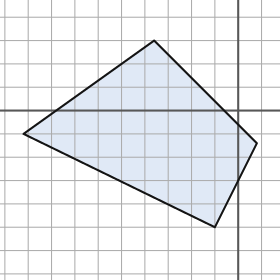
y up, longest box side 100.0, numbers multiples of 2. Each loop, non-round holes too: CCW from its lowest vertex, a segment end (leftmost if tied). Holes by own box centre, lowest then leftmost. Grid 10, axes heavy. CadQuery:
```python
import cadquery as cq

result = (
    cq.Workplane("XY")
    .moveTo(-10.0, -50.0)
    .lineTo(8.0, -14.0)
    .lineTo(-36.0, 30.0)
    .lineTo(-92.0, -10.0)
    .close()
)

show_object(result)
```